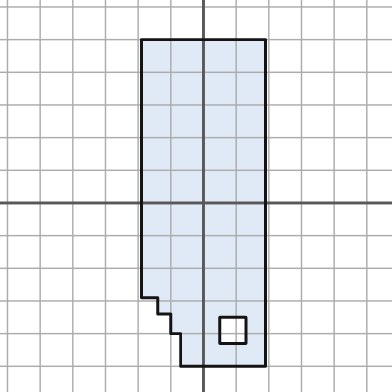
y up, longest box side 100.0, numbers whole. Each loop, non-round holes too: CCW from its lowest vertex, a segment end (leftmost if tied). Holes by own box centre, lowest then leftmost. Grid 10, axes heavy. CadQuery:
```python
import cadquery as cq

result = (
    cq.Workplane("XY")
    .moveTo(-7.0, -50.0)
    .lineTo(19.0, -50.0)
    .lineTo(19.0, 50.0)
    .lineTo(-19.0, 50.0)
    .lineTo(-19.0, -29.0)
    .lineTo(-14.0, -29.0)
    .lineTo(-14.0, -34.0)
    .lineTo(-10.0, -34.0)
    .lineTo(-10.0, -40.0)
    .lineTo(-7.0, -40.0)
    .close()
    .moveTo(5.0, -43.0)
    .lineTo(13.0, -43.0)
    .lineTo(13.0, -35.0)
    .lineTo(5.0, -35.0)
    .close()
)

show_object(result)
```